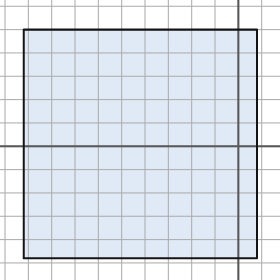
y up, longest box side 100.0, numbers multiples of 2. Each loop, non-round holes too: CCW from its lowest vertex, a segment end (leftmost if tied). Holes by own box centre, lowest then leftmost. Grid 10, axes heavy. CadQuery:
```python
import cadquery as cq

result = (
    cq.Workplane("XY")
    .moveTo(-92.0, -48.0)
    .lineTo(8.0, -48.0)
    .lineTo(8.0, 50.0)
    .lineTo(-92.0, 50.0)
    .close()
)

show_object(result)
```